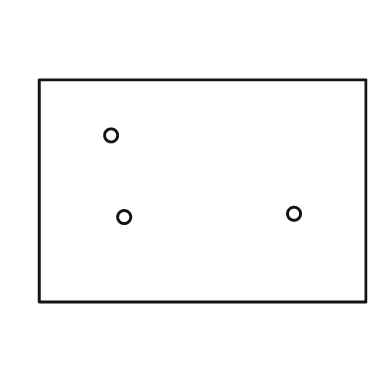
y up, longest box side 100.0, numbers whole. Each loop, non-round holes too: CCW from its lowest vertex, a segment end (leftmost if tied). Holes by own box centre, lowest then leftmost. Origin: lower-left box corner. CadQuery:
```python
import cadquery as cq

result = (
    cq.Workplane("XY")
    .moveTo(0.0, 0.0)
    .lineTo(100.0, 0.0)
    .lineTo(100.0, 68.0)
    .lineTo(0.0, 68.0)
    .close()
    .moveTo(26.0, 26.0)
    .circle(2.0)
    .moveTo(78.0, 27.0)
    .circle(2.0)
    .moveTo(22.0, 51.0)
    .circle(2.0)
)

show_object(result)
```